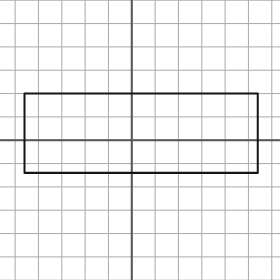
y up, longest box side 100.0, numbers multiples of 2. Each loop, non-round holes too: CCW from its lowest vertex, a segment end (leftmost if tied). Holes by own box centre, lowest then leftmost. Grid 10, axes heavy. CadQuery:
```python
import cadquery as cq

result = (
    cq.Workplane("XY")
    .moveTo(-46.0, -14.0)
    .lineTo(54.0, -14.0)
    .lineTo(54.0, 20.0)
    .lineTo(-46.0, 20.0)
    .close()
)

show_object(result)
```